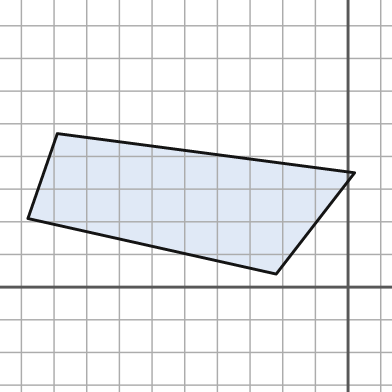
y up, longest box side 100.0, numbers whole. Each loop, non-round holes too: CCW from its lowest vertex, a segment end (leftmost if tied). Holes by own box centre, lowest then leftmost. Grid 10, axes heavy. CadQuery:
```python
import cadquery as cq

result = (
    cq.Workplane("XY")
    .moveTo(-22.0, 4.0)
    .lineTo(2.0, 35.0)
    .lineTo(-89.0, 47.0)
    .lineTo(-98.0, 21.0)
    .close()
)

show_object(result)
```